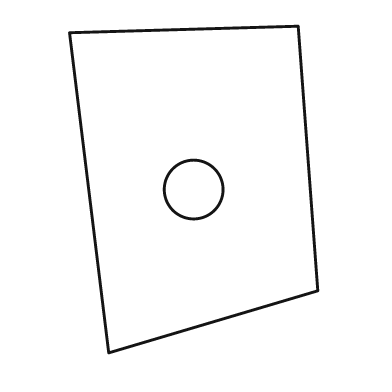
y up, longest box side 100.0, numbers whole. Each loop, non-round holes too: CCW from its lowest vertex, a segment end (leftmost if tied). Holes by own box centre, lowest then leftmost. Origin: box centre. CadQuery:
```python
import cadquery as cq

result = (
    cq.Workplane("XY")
    .moveTo(-26.0, -50.0)
    .lineTo(38.0, -31.0)
    .lineTo(32.0, 50.0)
    .lineTo(-38.0, 48.0)
    .close()
    .moveTo(0.0, 0.0)
    .circle(9.0)
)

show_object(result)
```